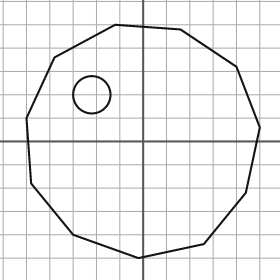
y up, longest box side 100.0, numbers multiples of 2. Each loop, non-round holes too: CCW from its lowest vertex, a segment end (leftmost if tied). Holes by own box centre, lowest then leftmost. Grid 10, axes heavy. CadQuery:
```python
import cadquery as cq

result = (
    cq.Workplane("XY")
    .moveTo(-2.0, -50.0)
    .lineTo(26.0, -44.0)
    .lineTo(44.0, -22.0)
    .lineTo(50.0, 6.0)
    .lineTo(40.0, 32.0)
    .lineTo(16.0, 48.0)
    .lineTo(-12.0, 50.0)
    .lineTo(-38.0, 36.0)
    .lineTo(-50.0, 10.0)
    .lineTo(-48.0, -18.0)
    .lineTo(-30.0, -40.0)
    .close()
    .moveTo(-22.0, 20.0)
    .circle(8.0)
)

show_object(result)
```